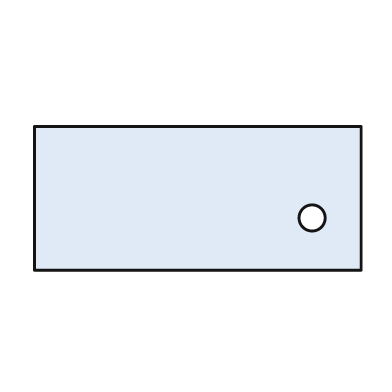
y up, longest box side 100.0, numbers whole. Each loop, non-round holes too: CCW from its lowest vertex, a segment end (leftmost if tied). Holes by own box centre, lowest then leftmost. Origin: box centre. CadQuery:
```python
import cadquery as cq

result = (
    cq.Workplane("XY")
    .moveTo(-50.0, -22.0)
    .lineTo(50.0, -22.0)
    .lineTo(50.0, 22.0)
    .lineTo(-50.0, 22.0)
    .close()
    .moveTo(35.0, -6.0)
    .circle(4.0)
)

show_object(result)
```